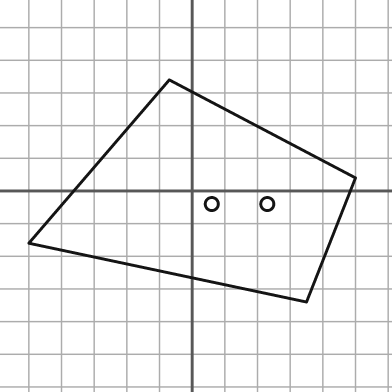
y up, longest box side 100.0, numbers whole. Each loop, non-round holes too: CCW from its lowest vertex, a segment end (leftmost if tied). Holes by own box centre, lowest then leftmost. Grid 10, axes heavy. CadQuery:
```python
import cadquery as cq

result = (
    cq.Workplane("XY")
    .moveTo(35.0, -34.0)
    .lineTo(50.0, 4.0)
    .lineTo(-7.0, 34.0)
    .lineTo(-50.0, -16.0)
    .close()
    .moveTo(6.0, -4.0)
    .circle(2.0)
    .moveTo(23.0, -4.0)
    .circle(2.0)
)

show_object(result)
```